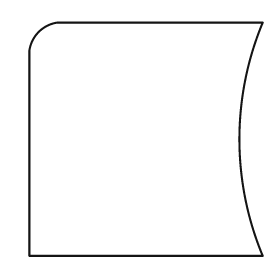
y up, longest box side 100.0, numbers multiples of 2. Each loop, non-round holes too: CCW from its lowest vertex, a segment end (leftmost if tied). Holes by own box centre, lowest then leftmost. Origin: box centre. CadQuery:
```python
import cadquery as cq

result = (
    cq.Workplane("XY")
    .moveTo(-50.0, -50.0)
    .lineTo(50.0, -50.0)
    .threePointArc((40.0, 0.0), (50.0, 50.0))
    .lineTo(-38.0, 50.0)
    .threePointArc((-46.0, 46.0), (-50.0, 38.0))
    .close()
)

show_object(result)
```